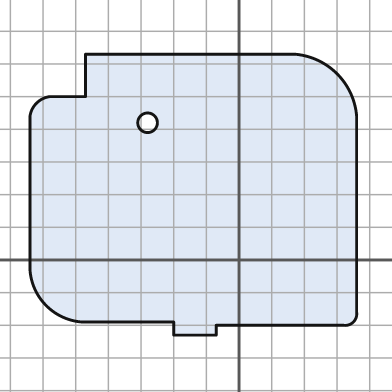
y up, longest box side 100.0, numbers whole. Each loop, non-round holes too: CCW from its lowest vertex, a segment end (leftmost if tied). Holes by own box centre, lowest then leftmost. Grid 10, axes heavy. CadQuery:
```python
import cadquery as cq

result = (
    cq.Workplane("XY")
    .moveTo(-20.0, -23.0)
    .lineTo(-7.0, -23.0)
    .lineTo(-7.0, -20.0)
    .lineTo(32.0, -20.0)
    .threePointArc((35.0, -19.0), (36.0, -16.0))
    .lineTo(36.0, 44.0)
    .threePointArc((30.0, 57.0), (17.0, 63.0))
    .lineTo(-47.0, 63.0)
    .lineTo(-47.0, 50.0)
    .lineTo(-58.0, 50.0)
    .threePointArc((-62.0, 48.0), (-64.0, 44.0))
    .lineTo(-64.0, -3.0)
    .threePointArc((-59.0, -14.0), (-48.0, -19.0))
    .lineTo(-20.0, -19.0)
    .close()
    .moveTo(-28.0, 42.0)
    .circle(3.0)
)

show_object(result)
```